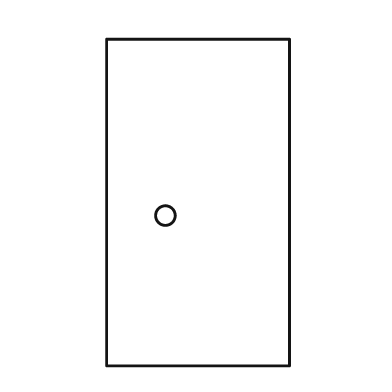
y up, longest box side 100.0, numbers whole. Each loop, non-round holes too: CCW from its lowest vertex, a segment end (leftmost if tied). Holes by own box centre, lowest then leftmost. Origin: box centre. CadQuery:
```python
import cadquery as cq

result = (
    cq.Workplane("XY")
    .moveTo(-28.0, -50.0)
    .lineTo(28.0, -50.0)
    .lineTo(28.0, 50.0)
    .lineTo(-28.0, 50.0)
    .close()
    .moveTo(-10.0, -4.0)
    .circle(3.0)
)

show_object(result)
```